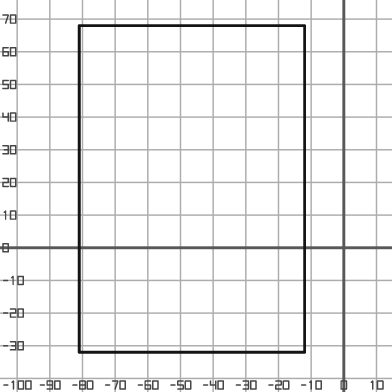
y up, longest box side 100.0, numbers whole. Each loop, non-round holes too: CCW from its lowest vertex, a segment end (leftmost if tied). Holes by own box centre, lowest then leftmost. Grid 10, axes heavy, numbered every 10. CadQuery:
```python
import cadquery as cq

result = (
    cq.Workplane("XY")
    .moveTo(-81.0, -32.0)
    .lineTo(-12.0, -32.0)
    .lineTo(-12.0, 68.0)
    .lineTo(-81.0, 68.0)
    .close()
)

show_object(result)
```